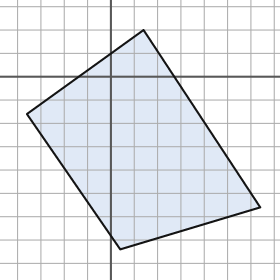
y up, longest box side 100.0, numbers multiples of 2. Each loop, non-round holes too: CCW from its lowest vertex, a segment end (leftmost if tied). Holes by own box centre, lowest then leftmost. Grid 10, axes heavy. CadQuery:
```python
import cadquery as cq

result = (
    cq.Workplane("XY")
    .moveTo(4.0, -74.0)
    .lineTo(64.0, -56.0)
    .lineTo(14.0, 20.0)
    .lineTo(-36.0, -16.0)
    .close()
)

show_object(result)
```